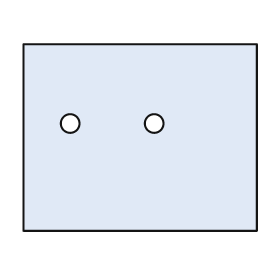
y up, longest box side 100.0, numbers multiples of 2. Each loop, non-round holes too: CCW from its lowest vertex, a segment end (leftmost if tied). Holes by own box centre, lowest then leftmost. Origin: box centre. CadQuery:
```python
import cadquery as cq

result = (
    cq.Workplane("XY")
    .moveTo(-50.0, -40.0)
    .lineTo(50.0, -40.0)
    .lineTo(50.0, 40.0)
    .lineTo(-50.0, 40.0)
    .close()
    .moveTo(-30.0, 6.0)
    .circle(4.0)
    .moveTo(6.0, 6.0)
    .circle(4.0)
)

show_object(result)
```